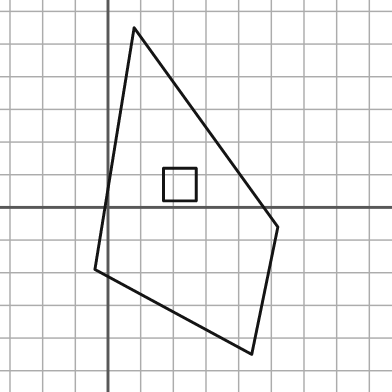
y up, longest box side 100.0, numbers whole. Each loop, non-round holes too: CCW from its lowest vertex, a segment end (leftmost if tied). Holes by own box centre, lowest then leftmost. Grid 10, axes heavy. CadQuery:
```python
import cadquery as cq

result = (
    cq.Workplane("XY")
    .moveTo(44.0, -45.0)
    .lineTo(52.0, -6.0)
    .lineTo(8.0, 55.0)
    .lineTo(-4.0, -19.0)
    .close()
    .moveTo(17.0, 2.0)
    .lineTo(27.0, 2.0)
    .lineTo(27.0, 12.0)
    .lineTo(17.0, 12.0)
    .close()
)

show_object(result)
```